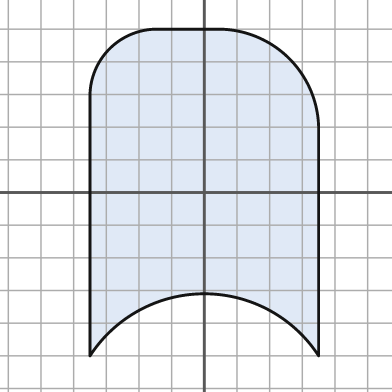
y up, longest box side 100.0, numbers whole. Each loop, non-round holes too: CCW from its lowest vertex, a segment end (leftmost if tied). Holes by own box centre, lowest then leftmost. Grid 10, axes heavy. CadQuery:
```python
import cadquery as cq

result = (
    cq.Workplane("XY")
    .moveTo(-35.0, -50.0)
    .threePointArc((0.0, -31.0), (35.0, -50.0))
    .lineTo(35.0, 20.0)
    .threePointArc((26.0, 41.0), (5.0, 50.0))
    .lineTo(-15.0, 50.0)
    .threePointArc((-29.0, 44.0), (-35.0, 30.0))
    .close()
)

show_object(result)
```